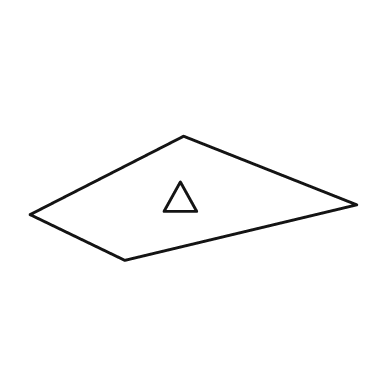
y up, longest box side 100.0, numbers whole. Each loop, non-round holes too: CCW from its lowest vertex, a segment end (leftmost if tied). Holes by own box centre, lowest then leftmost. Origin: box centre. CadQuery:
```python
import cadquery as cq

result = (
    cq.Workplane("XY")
    .moveTo(-21.0, -19.0)
    .lineTo(50.0, -2.0)
    .lineTo(-3.0, 19.0)
    .lineTo(-50.0, -5.0)
    .close()
    .moveTo(-9.0, -4.0)
    .lineTo(1.0, -4.0)
    .lineTo(-4.0, 5.0)
    .close()
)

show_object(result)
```